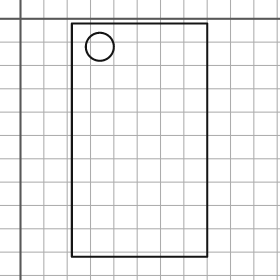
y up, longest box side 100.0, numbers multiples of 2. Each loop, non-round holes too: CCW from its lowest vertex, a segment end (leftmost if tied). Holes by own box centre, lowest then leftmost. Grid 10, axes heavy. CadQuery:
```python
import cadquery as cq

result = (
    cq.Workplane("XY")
    .moveTo(22.0, -102.0)
    .lineTo(80.0, -102.0)
    .lineTo(80.0, -2.0)
    .lineTo(22.0, -2.0)
    .close()
    .moveTo(34.0, -12.0)
    .circle(6.0)
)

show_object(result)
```